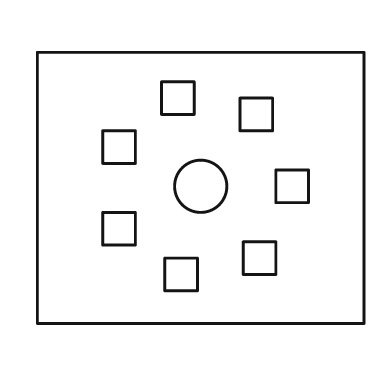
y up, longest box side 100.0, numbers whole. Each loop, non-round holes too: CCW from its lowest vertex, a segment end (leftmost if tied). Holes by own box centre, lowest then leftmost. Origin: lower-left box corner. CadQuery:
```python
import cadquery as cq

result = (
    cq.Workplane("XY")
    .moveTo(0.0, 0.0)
    .lineTo(100.0, 0.0)
    .lineTo(100.0, 83.0)
    .lineTo(0.0, 83.0)
    .close()
    .moveTo(39.0, 10.0)
    .lineTo(49.0, 10.0)
    .lineTo(49.0, 20.0)
    .lineTo(39.0, 20.0)
    .close()
    .moveTo(63.0, 15.0)
    .lineTo(73.0, 15.0)
    .lineTo(73.0, 25.0)
    .lineTo(63.0, 25.0)
    .close()
    .moveTo(20.0, 24.0)
    .lineTo(30.0, 24.0)
    .lineTo(30.0, 34.0)
    .lineTo(20.0, 34.0)
    .close()
    .moveTo(50.0, 42.0)
    .circle(8.0)
    .moveTo(73.0, 37.0)
    .lineTo(83.0, 37.0)
    .lineTo(83.0, 47.0)
    .lineTo(73.0, 47.0)
    .close()
    .moveTo(20.0, 49.0)
    .lineTo(30.0, 49.0)
    .lineTo(30.0, 59.0)
    .lineTo(20.0, 59.0)
    .close()
    .moveTo(62.0, 59.0)
    .lineTo(72.0, 59.0)
    .lineTo(72.0, 69.0)
    .lineTo(62.0, 69.0)
    .close()
    .moveTo(38.0, 64.0)
    .lineTo(48.0, 64.0)
    .lineTo(48.0, 74.0)
    .lineTo(38.0, 74.0)
    .close()
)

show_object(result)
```